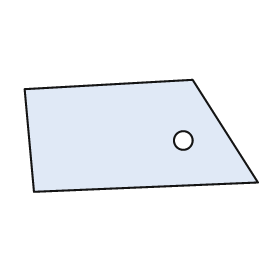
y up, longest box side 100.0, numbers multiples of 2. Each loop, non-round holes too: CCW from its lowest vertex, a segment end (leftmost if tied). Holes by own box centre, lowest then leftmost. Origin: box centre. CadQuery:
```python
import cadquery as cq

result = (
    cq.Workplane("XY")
    .moveTo(-46.0, -24.0)
    .lineTo(50.0, -20.0)
    .lineTo(22.0, 24.0)
    .lineTo(-50.0, 20.0)
    .close()
    .moveTo(18.0, -2.0)
    .circle(4.0)
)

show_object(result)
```